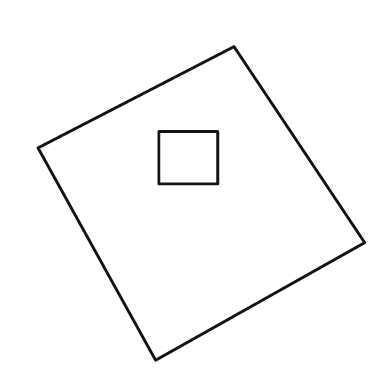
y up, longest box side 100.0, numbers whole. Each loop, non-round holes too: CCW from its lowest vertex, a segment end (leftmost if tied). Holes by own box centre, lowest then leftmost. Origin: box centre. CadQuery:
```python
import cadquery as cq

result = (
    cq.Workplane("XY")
    .moveTo(-14.0, -48.0)
    .lineTo(50.0, -12.0)
    .lineTo(10.0, 48.0)
    .lineTo(-50.0, 17.0)
    .close()
    .moveTo(-13.0, 6.0)
    .lineTo(5.0, 6.0)
    .lineTo(5.0, 22.0)
    .lineTo(-13.0, 22.0)
    .close()
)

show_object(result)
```